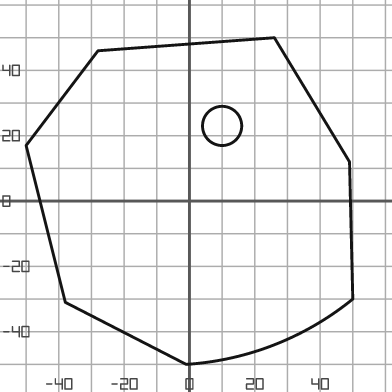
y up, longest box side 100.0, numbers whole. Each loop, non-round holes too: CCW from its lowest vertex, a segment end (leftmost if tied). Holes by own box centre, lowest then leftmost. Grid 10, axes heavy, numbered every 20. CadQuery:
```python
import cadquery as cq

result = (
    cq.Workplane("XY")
    .moveTo(-1.0, -50.0)
    .threePointArc((26.0, -44.0), (50.0, -30.0))
    .lineTo(49.0, 12.0)
    .lineTo(26.0, 50.0)
    .lineTo(-28.0, 46.0)
    .lineTo(-50.0, 17.0)
    .lineTo(-38.0, -31.0)
    .close()
    .moveTo(10.0, 23.0)
    .circle(6.0)
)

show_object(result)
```